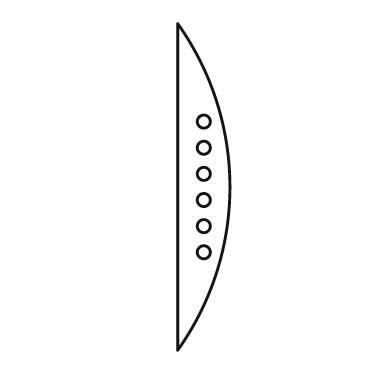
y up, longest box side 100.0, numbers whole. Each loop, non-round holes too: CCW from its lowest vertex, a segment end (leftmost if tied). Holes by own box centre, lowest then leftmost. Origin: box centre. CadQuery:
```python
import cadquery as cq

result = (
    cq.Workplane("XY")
    .moveTo(-8.0, -50.0)
    .threePointArc((8.0, 0.0), (-8.0, 50.0))
    .close()
    .moveTo(0.0, -20.0)
    .circle(2.0)
    .moveTo(0.0, -12.0)
    .circle(2.0)
    .moveTo(0.0, -4.0)
    .circle(2.0)
    .moveTo(0.0, 4.0)
    .circle(2.0)
    .moveTo(0.0, 12.0)
    .circle(2.0)
    .moveTo(0.0, 20.0)
    .circle(2.0)
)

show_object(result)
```